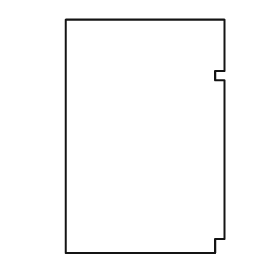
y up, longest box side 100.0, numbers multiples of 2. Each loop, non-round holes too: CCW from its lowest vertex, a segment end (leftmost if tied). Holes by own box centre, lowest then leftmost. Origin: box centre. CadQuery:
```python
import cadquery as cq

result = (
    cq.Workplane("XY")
    .moveTo(-34.0, -50.0)
    .lineTo(30.0, -50.0)
    .lineTo(30.0, -44.0)
    .lineTo(34.0, -44.0)
    .lineTo(34.0, 24.0)
    .lineTo(30.0, 24.0)
    .lineTo(30.0, 28.0)
    .lineTo(34.0, 28.0)
    .lineTo(34.0, 50.0)
    .lineTo(-34.0, 50.0)
    .close()
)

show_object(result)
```